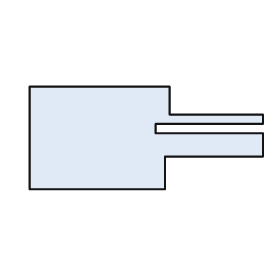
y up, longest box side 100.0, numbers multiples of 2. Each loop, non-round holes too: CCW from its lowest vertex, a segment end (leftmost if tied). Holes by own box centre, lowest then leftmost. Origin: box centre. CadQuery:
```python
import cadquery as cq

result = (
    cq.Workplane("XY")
    .moveTo(-50.0, -22.0)
    .lineTo(8.0, -22.0)
    .lineTo(8.0, -8.0)
    .lineTo(50.0, -8.0)
    .lineTo(50.0, 2.0)
    .lineTo(4.0, 2.0)
    .lineTo(4.0, 6.0)
    .lineTo(50.0, 6.0)
    .lineTo(50.0, 10.0)
    .lineTo(10.0, 10.0)
    .lineTo(10.0, 22.0)
    .lineTo(-50.0, 22.0)
    .close()
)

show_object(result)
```